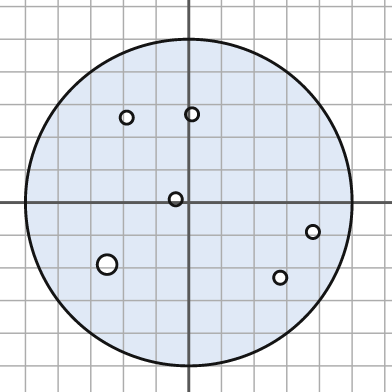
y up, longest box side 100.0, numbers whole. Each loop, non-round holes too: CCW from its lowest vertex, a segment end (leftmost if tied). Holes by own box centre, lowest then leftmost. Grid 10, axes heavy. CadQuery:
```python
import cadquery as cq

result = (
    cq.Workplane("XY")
    .moveTo(0.0, 0.0)
    .circle(50.0)
    .moveTo(28.0, -23.0)
    .circle(2.0)
    .moveTo(-25.0, -19.0)
    .circle(3.0)
    .moveTo(38.0, -9.0)
    .circle(2.0)
    .moveTo(-4.0, 1.0)
    .circle(2.0)
    .moveTo(-19.0, 26.0)
    .circle(2.0)
    .moveTo(1.0, 27.0)
    .circle(2.0)
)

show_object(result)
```